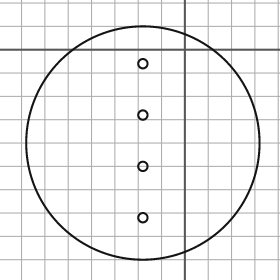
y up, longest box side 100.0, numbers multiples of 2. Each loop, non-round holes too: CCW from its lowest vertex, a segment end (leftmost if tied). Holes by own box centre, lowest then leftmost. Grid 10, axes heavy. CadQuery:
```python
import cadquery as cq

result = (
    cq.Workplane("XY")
    .moveTo(-18.0, -40.0)
    .circle(50.0)
    .moveTo(-18.0, -72.0)
    .circle(2.0)
    .moveTo(-18.0, -50.0)
    .circle(2.0)
    .moveTo(-18.0, -28.0)
    .circle(2.0)
    .moveTo(-18.0, -6.0)
    .circle(2.0)
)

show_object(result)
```